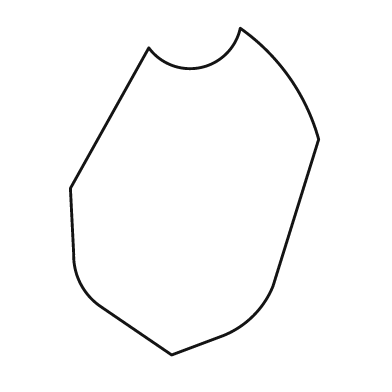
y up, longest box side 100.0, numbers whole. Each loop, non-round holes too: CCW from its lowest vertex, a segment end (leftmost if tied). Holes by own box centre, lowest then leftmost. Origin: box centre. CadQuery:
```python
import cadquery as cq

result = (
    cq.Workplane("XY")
    .moveTo(-7.0, -50.0)
    .lineTo(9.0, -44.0)
    .threePointArc((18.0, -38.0), (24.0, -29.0))
    .lineTo(38.0, 16.0)
    .threePointArc((29.0, 35.0), (14.0, 50.0))
    .threePointArc((2.0, 38.0), (-14.0, 44.0))
    .lineTo(-38.0, 1.0)
    .lineTo(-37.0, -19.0)
    .threePointArc((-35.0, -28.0), (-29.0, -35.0))
    .close()
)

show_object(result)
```